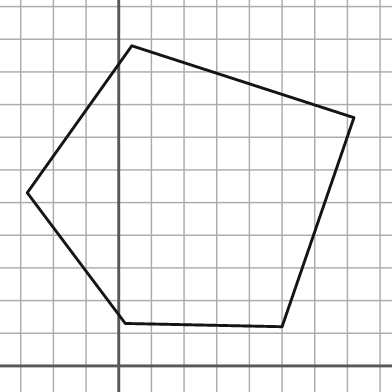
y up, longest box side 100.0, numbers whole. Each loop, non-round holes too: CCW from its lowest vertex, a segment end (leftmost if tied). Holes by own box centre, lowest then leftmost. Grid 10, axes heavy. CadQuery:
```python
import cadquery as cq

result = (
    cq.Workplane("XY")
    .moveTo(50.0, 12.0)
    .lineTo(72.0, 76.0)
    .lineTo(4.0, 98.0)
    .lineTo(-28.0, 53.0)
    .lineTo(2.0, 13.0)
    .close()
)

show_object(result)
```